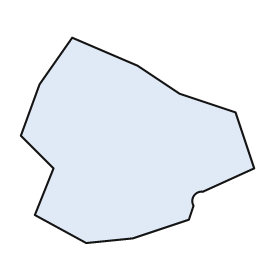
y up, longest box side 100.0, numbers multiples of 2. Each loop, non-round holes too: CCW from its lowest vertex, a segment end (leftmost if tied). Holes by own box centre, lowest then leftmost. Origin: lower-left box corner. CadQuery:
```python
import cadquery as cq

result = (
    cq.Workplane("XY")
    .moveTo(28.0, 0.0)
    .lineTo(48.0, 2.0)
    .lineTo(72.0, 10.0)
    .lineTo(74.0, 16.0)
    .threePointArc((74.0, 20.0), (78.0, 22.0))
    .lineTo(100.0, 32.0)
    .lineTo(92.0, 56.0)
    .lineTo(68.0, 64.0)
    .lineTo(50.0, 76.0)
    .lineTo(22.0, 88.0)
    .lineTo(8.0, 68.0)
    .lineTo(0.0, 46.0)
    .lineTo(14.0, 32.0)
    .lineTo(6.0, 12.0)
    .close()
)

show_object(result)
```